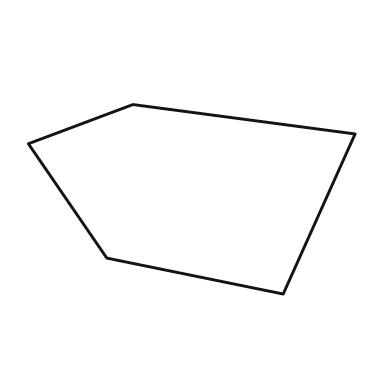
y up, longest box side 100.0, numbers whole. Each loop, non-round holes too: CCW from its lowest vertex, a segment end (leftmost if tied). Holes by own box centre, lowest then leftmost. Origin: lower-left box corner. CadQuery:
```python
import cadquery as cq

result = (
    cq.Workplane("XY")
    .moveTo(78.0, 0.0)
    .lineTo(100.0, 49.0)
    .lineTo(32.0, 58.0)
    .lineTo(0.0, 46.0)
    .lineTo(24.0, 11.0)
    .close()
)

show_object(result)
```